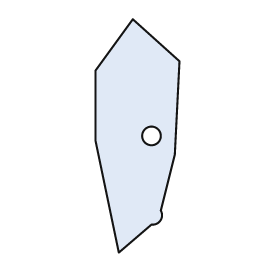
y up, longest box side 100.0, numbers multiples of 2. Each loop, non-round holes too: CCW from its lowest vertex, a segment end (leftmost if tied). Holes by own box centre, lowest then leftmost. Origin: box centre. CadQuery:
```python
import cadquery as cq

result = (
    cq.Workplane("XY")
    .moveTo(-8.0, -50.0)
    .lineTo(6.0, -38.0)
    .threePointArc((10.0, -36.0), (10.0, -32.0))
    .lineTo(16.0, -8.0)
    .lineTo(18.0, 32.0)
    .lineTo(-2.0, 50.0)
    .lineTo(-18.0, 28.0)
    .lineTo(-18.0, -2.0)
    .close()
    .moveTo(6.0, 0.0)
    .circle(4.0)
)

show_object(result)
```